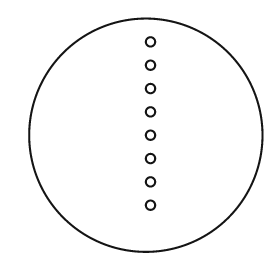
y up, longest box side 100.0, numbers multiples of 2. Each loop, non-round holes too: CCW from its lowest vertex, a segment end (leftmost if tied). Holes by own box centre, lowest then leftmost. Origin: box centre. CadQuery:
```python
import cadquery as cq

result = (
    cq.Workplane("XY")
    .moveTo(0.0, 0.0)
    .circle(50.0)
    .moveTo(2.0, -30.0)
    .circle(2.0)
    .moveTo(2.0, -20.0)
    .circle(2.0)
    .moveTo(2.0, -10.0)
    .circle(2.0)
    .moveTo(2.0, 0.0)
    .circle(2.0)
    .moveTo(2.0, 10.0)
    .circle(2.0)
    .moveTo(2.0, 20.0)
    .circle(2.0)
    .moveTo(2.0, 30.0)
    .circle(2.0)
    .moveTo(2.0, 40.0)
    .circle(2.0)
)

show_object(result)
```